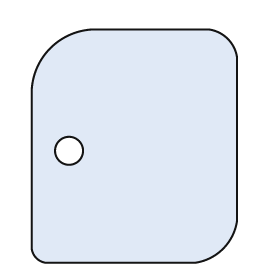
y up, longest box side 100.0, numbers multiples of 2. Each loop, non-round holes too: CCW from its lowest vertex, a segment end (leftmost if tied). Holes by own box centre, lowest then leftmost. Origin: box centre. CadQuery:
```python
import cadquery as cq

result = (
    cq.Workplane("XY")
    .moveTo(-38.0, -50.0)
    .lineTo(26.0, -50.0)
    .threePointArc((38.0, -44.0), (44.0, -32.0))
    .lineTo(44.0, 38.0)
    .threePointArc((40.0, 46.0), (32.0, 50.0))
    .lineTo(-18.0, 50.0)
    .threePointArc((-36.0, 42.0), (-44.0, 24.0))
    .lineTo(-44.0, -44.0)
    .threePointArc((-42.0, -48.0), (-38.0, -50.0))
    .close()
    .moveTo(-28.0, -2.0)
    .circle(6.0)
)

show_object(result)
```